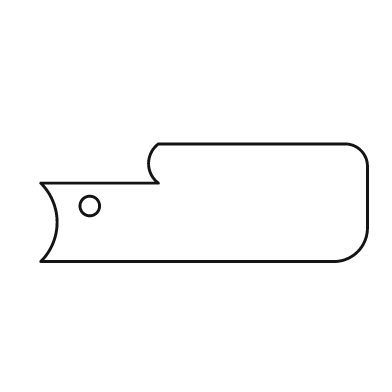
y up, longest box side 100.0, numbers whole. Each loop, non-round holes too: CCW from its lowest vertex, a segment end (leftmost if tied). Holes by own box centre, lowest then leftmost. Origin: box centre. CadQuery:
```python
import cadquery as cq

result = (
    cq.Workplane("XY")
    .moveTo(-50.0, -18.0)
    .lineTo(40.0, -18.0)
    .threePointArc((47.0, -15.0), (50.0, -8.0))
    .lineTo(50.0, 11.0)
    .threePointArc((48.0, 16.0), (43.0, 18.0))
    .lineTo(-14.0, 18.0)
    .threePointArc((-17.0, 12.0), (-14.0, 6.0))
    .lineTo(-50.0, 6.0)
    .threePointArc((-45.0, -6.0), (-50.0, -18.0))
    .close()
    .moveTo(-35.0, -1.0)
    .circle(3.0)
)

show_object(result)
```